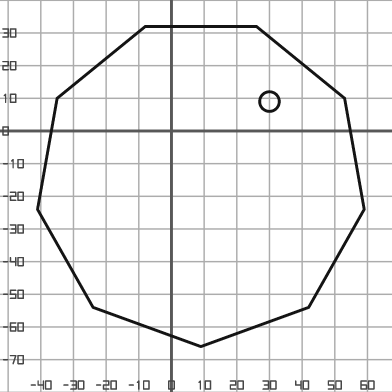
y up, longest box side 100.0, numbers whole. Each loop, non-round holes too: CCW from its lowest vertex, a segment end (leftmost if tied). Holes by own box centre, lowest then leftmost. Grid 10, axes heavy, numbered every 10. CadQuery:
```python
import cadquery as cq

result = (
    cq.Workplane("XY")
    .moveTo(9.0, -66.0)
    .lineTo(42.0, -54.0)
    .lineTo(59.0, -24.0)
    .lineTo(53.0, 10.0)
    .lineTo(26.0, 32.0)
    .lineTo(-8.0, 32.0)
    .lineTo(-35.0, 10.0)
    .lineTo(-41.0, -24.0)
    .lineTo(-24.0, -54.0)
    .close()
    .moveTo(30.0, 9.0)
    .circle(3.0)
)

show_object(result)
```